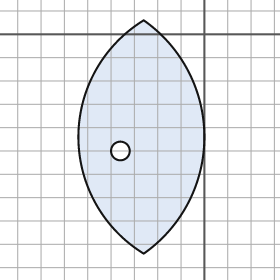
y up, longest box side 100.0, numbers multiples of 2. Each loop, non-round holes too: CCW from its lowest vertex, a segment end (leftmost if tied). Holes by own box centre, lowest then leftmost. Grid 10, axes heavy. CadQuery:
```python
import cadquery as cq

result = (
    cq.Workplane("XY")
    .moveTo(-26.0, -94.0)
    .threePointArc((0.0, -44.0), (-26.0, 6.0))
    .threePointArc((-54.0, -44.0), (-26.0, -94.0))
    .close()
    .moveTo(-36.0, -50.0)
    .circle(4.0)
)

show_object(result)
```